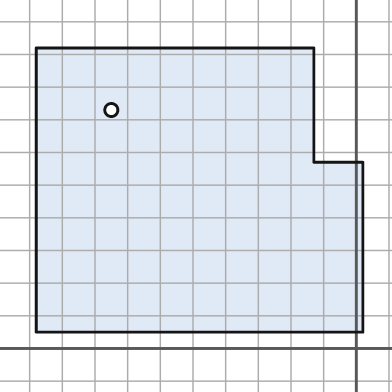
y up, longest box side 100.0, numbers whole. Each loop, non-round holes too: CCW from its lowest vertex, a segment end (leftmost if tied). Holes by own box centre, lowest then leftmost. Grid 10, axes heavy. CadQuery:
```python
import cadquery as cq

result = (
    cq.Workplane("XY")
    .moveTo(-98.0, 5.0)
    .lineTo(2.0, 5.0)
    .lineTo(2.0, 57.0)
    .lineTo(-13.0, 57.0)
    .lineTo(-13.0, 92.0)
    .lineTo(-98.0, 92.0)
    .close()
    .moveTo(-75.0, 73.0)
    .circle(2.0)
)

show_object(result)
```